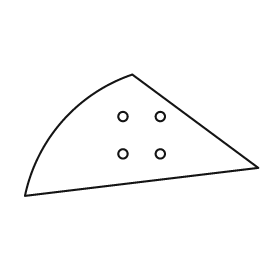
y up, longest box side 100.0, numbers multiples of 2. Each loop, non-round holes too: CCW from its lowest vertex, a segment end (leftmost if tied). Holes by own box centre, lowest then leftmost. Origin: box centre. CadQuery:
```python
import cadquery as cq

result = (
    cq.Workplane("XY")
    .moveTo(-50.0, -26.0)
    .lineTo(50.0, -14.0)
    .lineTo(-4.0, 26.0)
    .threePointArc((-34.0, 6.0), (-50.0, -26.0))
    .close()
    .moveTo(-8.0, -8.0)
    .circle(2.0)
    .moveTo(8.0, -8.0)
    .circle(2.0)
    .moveTo(-8.0, 8.0)
    .circle(2.0)
    .moveTo(8.0, 8.0)
    .circle(2.0)
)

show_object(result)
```